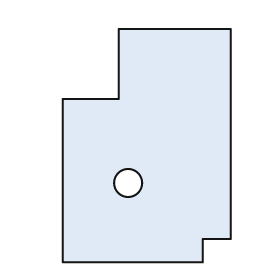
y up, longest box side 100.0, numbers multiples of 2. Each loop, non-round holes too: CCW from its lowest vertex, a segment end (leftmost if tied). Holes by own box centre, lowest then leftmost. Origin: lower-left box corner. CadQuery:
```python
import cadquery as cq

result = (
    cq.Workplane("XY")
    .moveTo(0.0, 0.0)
    .lineTo(60.0, 0.0)
    .lineTo(60.0, 10.0)
    .lineTo(72.0, 10.0)
    .lineTo(72.0, 100.0)
    .lineTo(24.0, 100.0)
    .lineTo(24.0, 70.0)
    .lineTo(0.0, 70.0)
    .close()
    .moveTo(28.0, 34.0)
    .circle(6.0)
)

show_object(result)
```